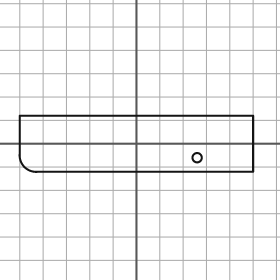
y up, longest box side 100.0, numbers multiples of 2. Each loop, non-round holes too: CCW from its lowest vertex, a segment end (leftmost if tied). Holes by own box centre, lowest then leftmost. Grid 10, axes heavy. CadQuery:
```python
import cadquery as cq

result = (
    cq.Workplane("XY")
    .moveTo(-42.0, -12.0)
    .lineTo(50.0, -12.0)
    .lineTo(50.0, 12.0)
    .lineTo(-50.0, 12.0)
    .lineTo(-50.0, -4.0)
    .threePointArc((-48.0, -10.0), (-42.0, -12.0))
    .close()
    .moveTo(26.0, -6.0)
    .circle(2.0)
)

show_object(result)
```